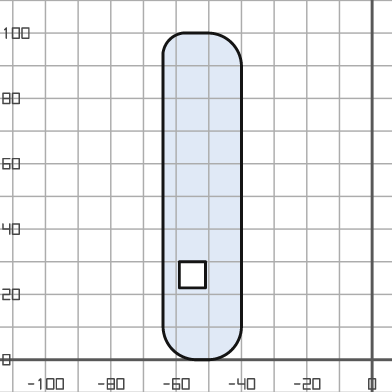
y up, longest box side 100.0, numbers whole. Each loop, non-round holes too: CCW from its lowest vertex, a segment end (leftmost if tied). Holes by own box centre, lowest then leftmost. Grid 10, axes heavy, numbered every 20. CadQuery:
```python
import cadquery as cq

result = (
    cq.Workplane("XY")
    .moveTo(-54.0, 0.0)
    .lineTo(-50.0, 0.0)
    .threePointArc((-43.0, 3.0), (-40.0, 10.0))
    .lineTo(-40.0, 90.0)
    .threePointArc((-43.0, 97.0), (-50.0, 100.0))
    .lineTo(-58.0, 100.0)
    .threePointArc((-62.0, 98.0), (-64.0, 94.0))
    .lineTo(-64.0, 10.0)
    .threePointArc((-61.0, 3.0), (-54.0, 0.0))
    .close()
    .moveTo(-59.0, 22.0)
    .lineTo(-51.0, 22.0)
    .lineTo(-51.0, 30.0)
    .lineTo(-59.0, 30.0)
    .close()
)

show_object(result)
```